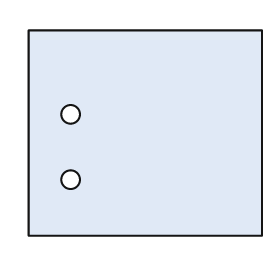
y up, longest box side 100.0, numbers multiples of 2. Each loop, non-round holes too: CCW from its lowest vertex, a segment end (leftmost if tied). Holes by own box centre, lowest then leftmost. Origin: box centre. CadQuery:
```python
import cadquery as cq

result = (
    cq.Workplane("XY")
    .moveTo(-50.0, -44.0)
    .lineTo(50.0, -44.0)
    .lineTo(50.0, 44.0)
    .lineTo(-50.0, 44.0)
    .close()
    .moveTo(-32.0, -20.0)
    .circle(4.0)
    .moveTo(-32.0, 8.0)
    .circle(4.0)
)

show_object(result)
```